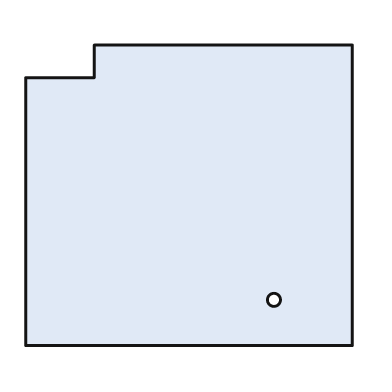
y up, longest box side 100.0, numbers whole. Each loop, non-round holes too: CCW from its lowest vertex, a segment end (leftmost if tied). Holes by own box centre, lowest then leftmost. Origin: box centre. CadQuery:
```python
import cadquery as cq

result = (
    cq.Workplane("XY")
    .moveTo(-50.0, -46.0)
    .lineTo(50.0, -46.0)
    .lineTo(50.0, 46.0)
    .lineTo(-29.0, 46.0)
    .lineTo(-29.0, 36.0)
    .lineTo(-50.0, 36.0)
    .close()
    .moveTo(26.0, -32.0)
    .circle(2.0)
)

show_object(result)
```